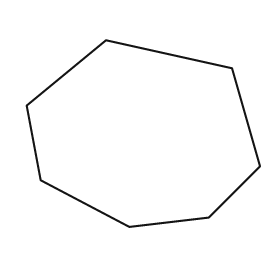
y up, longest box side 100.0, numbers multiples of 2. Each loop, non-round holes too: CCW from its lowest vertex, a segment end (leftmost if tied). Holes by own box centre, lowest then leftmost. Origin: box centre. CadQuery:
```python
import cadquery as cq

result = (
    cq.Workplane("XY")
    .moveTo(-6.0, -40.0)
    .lineTo(28.0, -36.0)
    .lineTo(50.0, -14.0)
    .lineTo(38.0, 28.0)
    .lineTo(-16.0, 40.0)
    .lineTo(-50.0, 12.0)
    .lineTo(-44.0, -20.0)
    .close()
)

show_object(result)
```